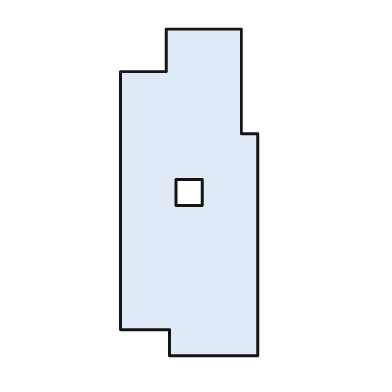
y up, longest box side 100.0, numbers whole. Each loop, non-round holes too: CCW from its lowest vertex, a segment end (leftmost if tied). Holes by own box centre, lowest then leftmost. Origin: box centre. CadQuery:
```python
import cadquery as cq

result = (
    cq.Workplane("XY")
    .moveTo(-6.0, -50.0)
    .lineTo(21.0, -50.0)
    .lineTo(21.0, 18.0)
    .lineTo(16.0, 18.0)
    .lineTo(16.0, 50.0)
    .lineTo(-7.0, 50.0)
    .lineTo(-7.0, 37.0)
    .lineTo(-21.0, 37.0)
    .lineTo(-21.0, -42.0)
    .lineTo(-6.0, -42.0)
    .close()
    .moveTo(-4.0, -4.0)
    .lineTo(4.0, -4.0)
    .lineTo(4.0, 4.0)
    .lineTo(-4.0, 4.0)
    .close()
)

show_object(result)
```